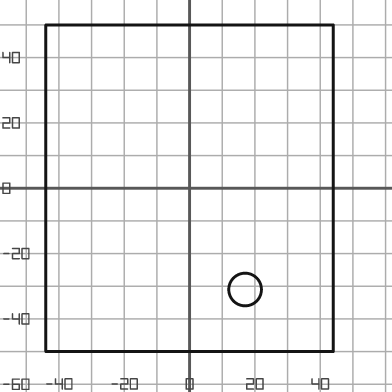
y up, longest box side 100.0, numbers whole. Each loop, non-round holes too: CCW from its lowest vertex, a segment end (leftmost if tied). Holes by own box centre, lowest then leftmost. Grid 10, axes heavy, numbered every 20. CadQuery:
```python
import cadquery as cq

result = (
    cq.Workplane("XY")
    .moveTo(-44.0, -50.0)
    .lineTo(44.0, -50.0)
    .lineTo(44.0, 50.0)
    .lineTo(-44.0, 50.0)
    .close()
    .moveTo(17.0, -31.0)
    .circle(5.0)
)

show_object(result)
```